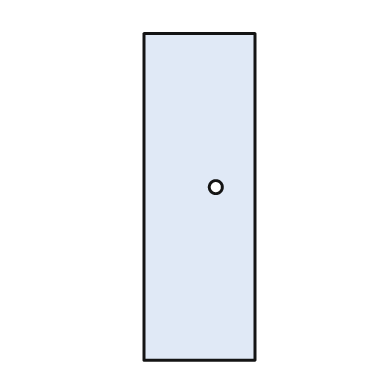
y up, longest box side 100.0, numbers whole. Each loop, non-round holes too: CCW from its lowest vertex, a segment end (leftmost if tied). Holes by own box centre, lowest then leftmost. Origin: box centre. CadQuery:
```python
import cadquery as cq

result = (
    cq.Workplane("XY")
    .moveTo(-17.0, -50.0)
    .lineTo(17.0, -50.0)
    .lineTo(17.0, 50.0)
    .lineTo(-17.0, 50.0)
    .close()
    .moveTo(5.0, 3.0)
    .circle(2.0)
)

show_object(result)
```